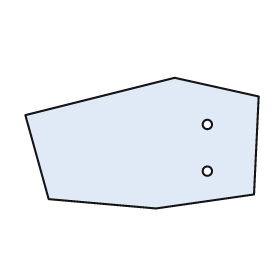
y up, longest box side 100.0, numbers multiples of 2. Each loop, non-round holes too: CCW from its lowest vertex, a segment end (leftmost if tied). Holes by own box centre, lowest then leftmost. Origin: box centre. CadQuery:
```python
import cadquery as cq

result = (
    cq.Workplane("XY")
    .moveTo(6.0, -28.0)
    .lineTo(48.0, -22.0)
    .lineTo(50.0, 20.0)
    .lineTo(14.0, 28.0)
    .lineTo(-50.0, 12.0)
    .lineTo(-40.0, -24.0)
    .close()
    .moveTo(28.0, -12.0)
    .circle(2.0)
    .moveTo(28.0, 8.0)
    .circle(2.0)
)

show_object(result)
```